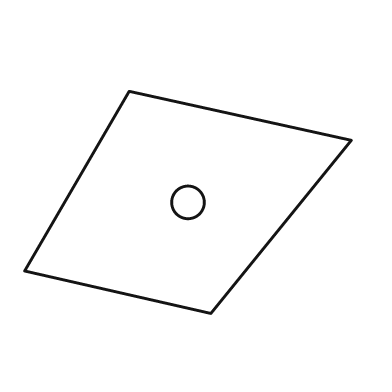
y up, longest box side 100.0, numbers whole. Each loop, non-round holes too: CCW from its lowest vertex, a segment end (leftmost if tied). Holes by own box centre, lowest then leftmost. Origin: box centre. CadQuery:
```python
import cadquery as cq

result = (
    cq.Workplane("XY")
    .moveTo(7.0, -34.0)
    .lineTo(50.0, 19.0)
    .lineTo(-18.0, 34.0)
    .lineTo(-50.0, -21.0)
    .close()
    .moveTo(0.0, 0.0)
    .circle(5.0)
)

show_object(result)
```